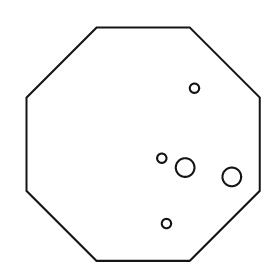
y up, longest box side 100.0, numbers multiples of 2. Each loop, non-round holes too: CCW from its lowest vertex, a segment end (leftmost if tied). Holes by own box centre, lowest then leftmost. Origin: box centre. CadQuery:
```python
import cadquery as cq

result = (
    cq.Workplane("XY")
    .moveTo(-20.0, -50.0)
    .lineTo(20.0, -50.0)
    .lineTo(50.0, -20.0)
    .lineTo(50.0, 20.0)
    .lineTo(20.0, 50.0)
    .lineTo(-20.0, 50.0)
    .lineTo(-50.0, 20.0)
    .lineTo(-50.0, -20.0)
    .close()
    .moveTo(10.0, -34.0)
    .circle(2.0)
    .moveTo(38.0, -14.0)
    .circle(4.0)
    .moveTo(18.0, -10.0)
    .circle(4.0)
    .moveTo(8.0, -6.0)
    .circle(2.0)
    .moveTo(22.0, 24.0)
    .circle(2.0)
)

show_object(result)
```